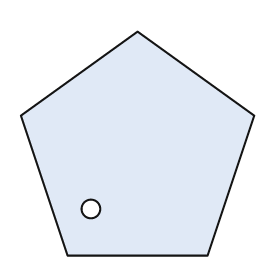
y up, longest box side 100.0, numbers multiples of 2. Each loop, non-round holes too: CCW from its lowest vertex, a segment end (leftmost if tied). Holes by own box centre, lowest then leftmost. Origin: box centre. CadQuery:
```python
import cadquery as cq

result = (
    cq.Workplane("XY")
    .moveTo(-30.0, -48.0)
    .lineTo(30.0, -48.0)
    .lineTo(50.0, 12.0)
    .lineTo(0.0, 48.0)
    .lineTo(-50.0, 12.0)
    .close()
    .moveTo(-20.0, -28.0)
    .circle(4.0)
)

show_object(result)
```